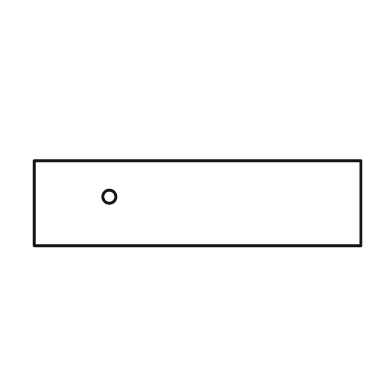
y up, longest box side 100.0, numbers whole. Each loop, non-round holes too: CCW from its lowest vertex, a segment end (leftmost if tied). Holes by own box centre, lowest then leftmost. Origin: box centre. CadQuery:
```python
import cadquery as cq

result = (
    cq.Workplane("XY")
    .moveTo(-50.0, -13.0)
    .lineTo(50.0, -13.0)
    .lineTo(50.0, 13.0)
    .lineTo(-50.0, 13.0)
    .close()
    .moveTo(-27.0, 2.0)
    .circle(2.0)
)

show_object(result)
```